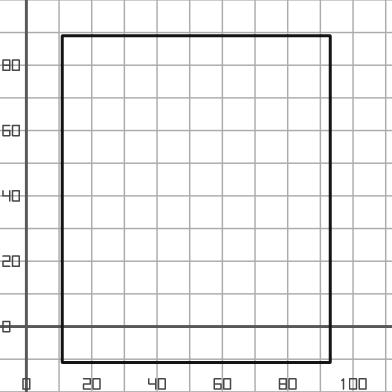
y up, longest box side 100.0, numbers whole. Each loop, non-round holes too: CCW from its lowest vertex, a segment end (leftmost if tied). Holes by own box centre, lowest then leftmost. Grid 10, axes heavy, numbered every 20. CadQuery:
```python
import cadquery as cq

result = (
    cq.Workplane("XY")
    .moveTo(11.0, -11.0)
    .lineTo(93.0, -11.0)
    .lineTo(93.0, 89.0)
    .lineTo(11.0, 89.0)
    .close()
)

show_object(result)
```